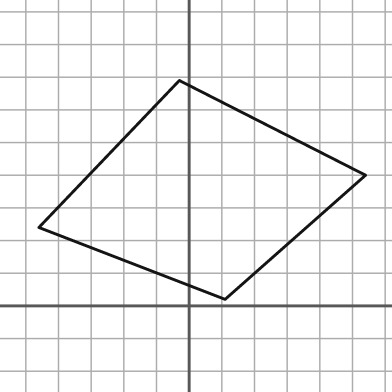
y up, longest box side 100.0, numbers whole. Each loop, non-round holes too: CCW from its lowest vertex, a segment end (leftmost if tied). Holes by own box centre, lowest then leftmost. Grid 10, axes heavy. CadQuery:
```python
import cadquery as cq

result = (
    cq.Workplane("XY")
    .moveTo(11.0, 2.0)
    .lineTo(54.0, 40.0)
    .lineTo(-3.0, 69.0)
    .lineTo(-46.0, 24.0)
    .close()
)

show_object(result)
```